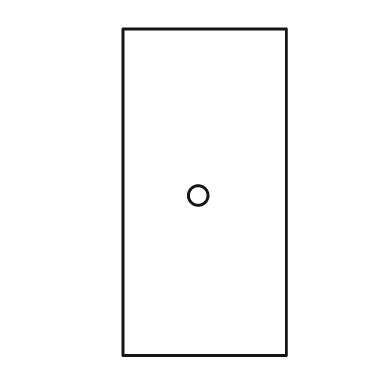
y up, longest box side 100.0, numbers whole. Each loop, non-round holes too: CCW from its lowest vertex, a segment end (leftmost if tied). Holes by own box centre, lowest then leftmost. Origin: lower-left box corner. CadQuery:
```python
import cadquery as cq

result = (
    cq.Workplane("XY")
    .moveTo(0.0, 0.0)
    .lineTo(50.0, 0.0)
    .lineTo(50.0, 100.0)
    .lineTo(0.0, 100.0)
    .close()
    .moveTo(23.0, 49.0)
    .circle(3.0)
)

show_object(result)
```